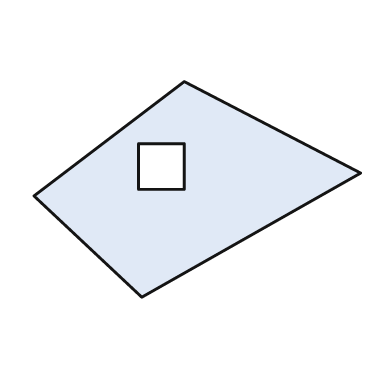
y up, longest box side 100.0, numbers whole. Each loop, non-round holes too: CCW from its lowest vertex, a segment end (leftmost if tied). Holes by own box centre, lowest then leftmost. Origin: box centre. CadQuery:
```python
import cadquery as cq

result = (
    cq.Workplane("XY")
    .moveTo(-17.0, -33.0)
    .lineTo(50.0, 5.0)
    .lineTo(-4.0, 33.0)
    .lineTo(-50.0, -2.0)
    .close()
    .moveTo(-18.0, 0.0)
    .lineTo(-4.0, 0.0)
    .lineTo(-4.0, 14.0)
    .lineTo(-18.0, 14.0)
    .close()
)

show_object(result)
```